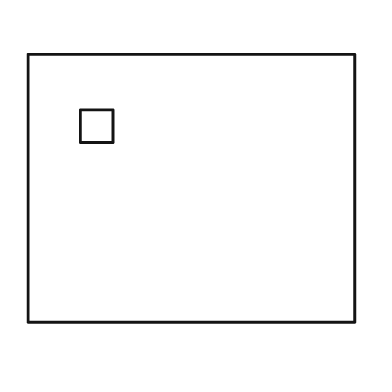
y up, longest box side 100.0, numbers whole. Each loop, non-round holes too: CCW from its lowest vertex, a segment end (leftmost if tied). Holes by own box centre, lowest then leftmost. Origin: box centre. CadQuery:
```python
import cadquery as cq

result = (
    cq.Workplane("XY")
    .moveTo(-50.0, -41.0)
    .lineTo(50.0, -41.0)
    .lineTo(50.0, 41.0)
    .lineTo(-50.0, 41.0)
    .close()
    .moveTo(-34.0, 14.0)
    .lineTo(-24.0, 14.0)
    .lineTo(-24.0, 24.0)
    .lineTo(-34.0, 24.0)
    .close()
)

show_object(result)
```